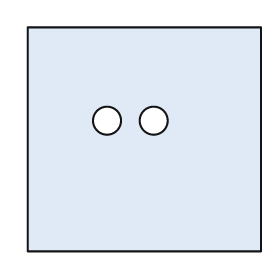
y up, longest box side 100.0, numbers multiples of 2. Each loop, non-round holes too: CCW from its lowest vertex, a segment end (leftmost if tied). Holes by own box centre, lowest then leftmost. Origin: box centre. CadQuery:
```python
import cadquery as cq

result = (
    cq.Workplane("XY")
    .moveTo(-50.0, -48.0)
    .lineTo(50.0, -48.0)
    .lineTo(50.0, 48.0)
    .lineTo(-50.0, 48.0)
    .close()
    .moveTo(-16.0, 8.0)
    .circle(6.0)
    .moveTo(4.0, 8.0)
    .circle(6.0)
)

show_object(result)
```